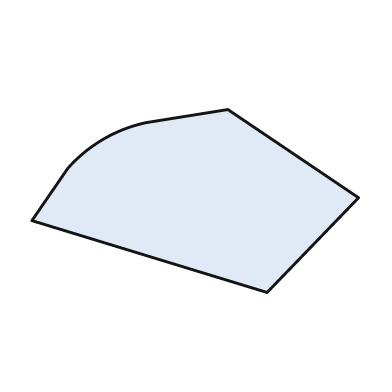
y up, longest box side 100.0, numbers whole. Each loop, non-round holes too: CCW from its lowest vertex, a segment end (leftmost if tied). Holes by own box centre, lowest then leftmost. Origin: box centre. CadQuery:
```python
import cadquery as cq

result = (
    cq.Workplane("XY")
    .moveTo(22.0, -28.0)
    .lineTo(50.0, 1.0)
    .lineTo(10.0, 28.0)
    .lineTo(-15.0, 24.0)
    .threePointArc((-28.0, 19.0), (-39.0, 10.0))
    .lineTo(-50.0, -6.0)
    .close()
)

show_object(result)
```